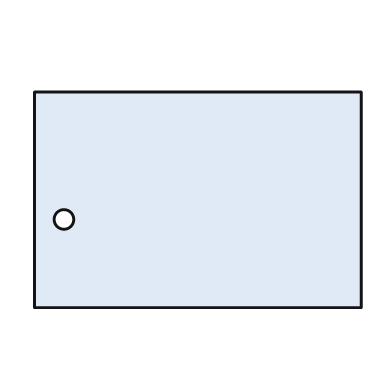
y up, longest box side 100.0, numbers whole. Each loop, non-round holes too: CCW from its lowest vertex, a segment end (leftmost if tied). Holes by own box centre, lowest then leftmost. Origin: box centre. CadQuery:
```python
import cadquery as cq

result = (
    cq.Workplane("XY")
    .moveTo(-50.0, -33.0)
    .lineTo(50.0, -33.0)
    .lineTo(50.0, 33.0)
    .lineTo(-50.0, 33.0)
    .close()
    .moveTo(-41.0, -6.0)
    .circle(3.0)
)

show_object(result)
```